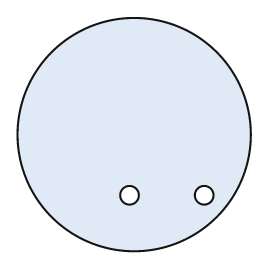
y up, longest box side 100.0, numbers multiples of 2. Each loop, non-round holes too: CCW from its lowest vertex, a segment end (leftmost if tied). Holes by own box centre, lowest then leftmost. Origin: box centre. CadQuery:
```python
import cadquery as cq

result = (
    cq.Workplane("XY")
    .moveTo(0.0, 0.0)
    .circle(50.0)
    .moveTo(-2.0, -26.0)
    .circle(4.0)
    .moveTo(30.0, -26.0)
    .circle(4.0)
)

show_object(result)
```